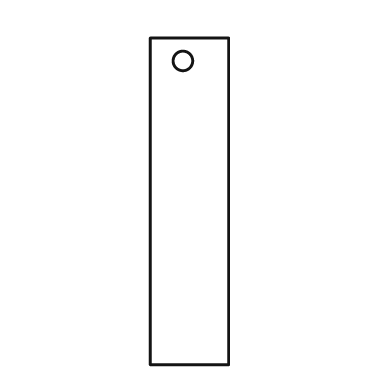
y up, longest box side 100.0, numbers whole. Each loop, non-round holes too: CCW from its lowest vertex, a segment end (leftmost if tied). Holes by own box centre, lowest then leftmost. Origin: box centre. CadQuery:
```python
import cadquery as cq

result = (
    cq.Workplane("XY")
    .moveTo(-12.0, -50.0)
    .lineTo(12.0, -50.0)
    .lineTo(12.0, 50.0)
    .lineTo(-12.0, 50.0)
    .close()
    .moveTo(-2.0, 43.0)
    .circle(3.0)
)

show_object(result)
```